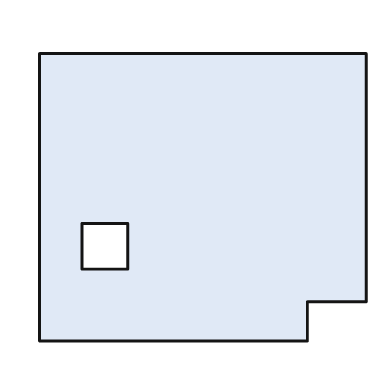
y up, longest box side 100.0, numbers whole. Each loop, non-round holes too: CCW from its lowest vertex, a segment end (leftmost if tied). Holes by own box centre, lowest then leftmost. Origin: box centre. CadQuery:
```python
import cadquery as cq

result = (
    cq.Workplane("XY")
    .moveTo(-50.0, -44.0)
    .lineTo(32.0, -44.0)
    .lineTo(32.0, -32.0)
    .lineTo(50.0, -32.0)
    .lineTo(50.0, 44.0)
    .lineTo(-50.0, 44.0)
    .close()
    .moveTo(-37.0, -22.0)
    .lineTo(-23.0, -22.0)
    .lineTo(-23.0, -8.0)
    .lineTo(-37.0, -8.0)
    .close()
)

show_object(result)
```